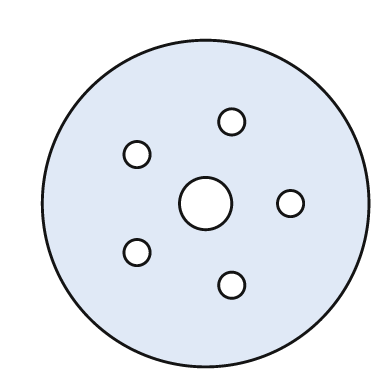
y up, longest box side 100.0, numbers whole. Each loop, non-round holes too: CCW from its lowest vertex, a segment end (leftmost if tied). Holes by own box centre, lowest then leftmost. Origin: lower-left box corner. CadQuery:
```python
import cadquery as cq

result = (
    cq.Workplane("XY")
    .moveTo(50.0, 50.0)
    .circle(50.0)
    .moveTo(58.0, 25.0)
    .circle(4.0)
    .moveTo(29.0, 35.0)
    .circle(4.0)
    .moveTo(50.0, 50.0)
    .circle(8.0)
    .moveTo(76.0, 50.0)
    .circle(4.0)
    .moveTo(29.0, 65.0)
    .circle(4.0)
    .moveTo(58.0, 75.0)
    .circle(4.0)
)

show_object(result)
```